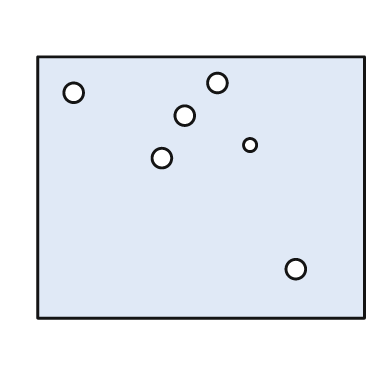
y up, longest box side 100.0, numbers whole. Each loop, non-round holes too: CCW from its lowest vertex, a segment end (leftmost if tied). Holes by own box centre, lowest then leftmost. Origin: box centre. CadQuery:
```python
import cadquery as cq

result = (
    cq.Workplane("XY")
    .moveTo(-50.0, -40.0)
    .lineTo(50.0, -40.0)
    .lineTo(50.0, 40.0)
    .lineTo(-50.0, 40.0)
    .close()
    .moveTo(29.0, -25.0)
    .circle(3.0)
    .moveTo(-12.0, 9.0)
    .circle(3.0)
    .moveTo(15.0, 13.0)
    .circle(2.0)
    .moveTo(-5.0, 22.0)
    .circle(3.0)
    .moveTo(-39.0, 29.0)
    .circle(3.0)
    .moveTo(5.0, 32.0)
    .circle(3.0)
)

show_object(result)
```